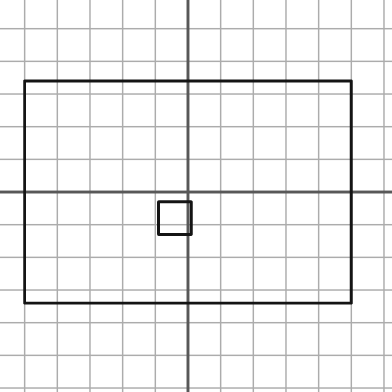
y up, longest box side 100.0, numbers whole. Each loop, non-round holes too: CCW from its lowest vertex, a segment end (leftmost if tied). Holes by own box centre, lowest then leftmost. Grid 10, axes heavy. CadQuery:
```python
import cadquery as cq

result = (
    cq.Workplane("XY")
    .moveTo(-50.0, -34.0)
    .lineTo(50.0, -34.0)
    .lineTo(50.0, 34.0)
    .lineTo(-50.0, 34.0)
    .close()
    .moveTo(-9.0, -13.0)
    .lineTo(1.0, -13.0)
    .lineTo(1.0, -3.0)
    .lineTo(-9.0, -3.0)
    .close()
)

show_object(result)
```